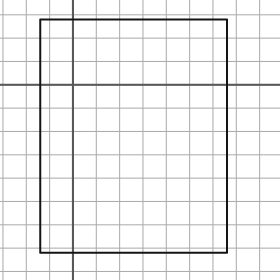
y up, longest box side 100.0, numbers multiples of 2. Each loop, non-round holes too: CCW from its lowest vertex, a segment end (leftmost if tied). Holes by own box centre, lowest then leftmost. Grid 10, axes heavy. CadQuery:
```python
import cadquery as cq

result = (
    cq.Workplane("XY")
    .moveTo(-14.0, -72.0)
    .lineTo(66.0, -72.0)
    .lineTo(66.0, 28.0)
    .lineTo(-14.0, 28.0)
    .close()
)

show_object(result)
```